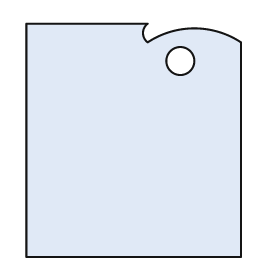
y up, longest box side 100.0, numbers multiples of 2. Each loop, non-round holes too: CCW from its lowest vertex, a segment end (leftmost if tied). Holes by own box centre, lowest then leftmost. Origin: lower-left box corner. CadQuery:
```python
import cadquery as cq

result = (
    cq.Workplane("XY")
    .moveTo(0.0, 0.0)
    .lineTo(92.0, 0.0)
    .lineTo(92.0, 92.0)
    .threePointArc((72.0, 98.0), (52.0, 92.0))
    .threePointArc((50.0, 96.0), (52.0, 100.0))
    .lineTo(0.0, 100.0)
    .close()
    .moveTo(66.0, 84.0)
    .circle(6.0)
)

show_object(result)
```